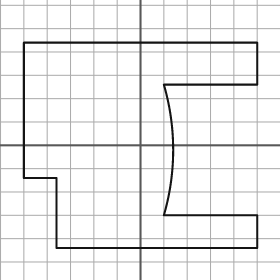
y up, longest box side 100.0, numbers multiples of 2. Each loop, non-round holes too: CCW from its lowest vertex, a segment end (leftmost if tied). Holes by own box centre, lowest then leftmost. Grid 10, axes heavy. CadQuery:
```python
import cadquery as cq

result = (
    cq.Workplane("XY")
    .moveTo(-36.0, -44.0)
    .lineTo(50.0, -44.0)
    .lineTo(50.0, -30.0)
    .lineTo(10.0, -30.0)
    .threePointArc((14.0, -2.0), (10.0, 26.0))
    .lineTo(50.0, 26.0)
    .lineTo(50.0, 44.0)
    .lineTo(-50.0, 44.0)
    .lineTo(-50.0, -14.0)
    .lineTo(-36.0, -14.0)
    .close()
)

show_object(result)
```